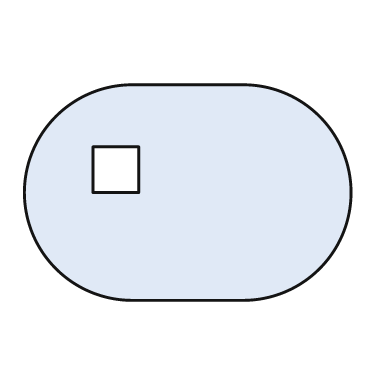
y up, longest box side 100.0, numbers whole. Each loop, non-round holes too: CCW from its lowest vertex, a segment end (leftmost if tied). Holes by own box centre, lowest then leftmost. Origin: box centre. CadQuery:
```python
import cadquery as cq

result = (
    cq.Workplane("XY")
    .moveTo(-17.0, -33.0)
    .lineTo(17.0, -33.0)
    .threePointArc((50.0, 0.0), (17.0, 33.0))
    .lineTo(-17.0, 33.0)
    .threePointArc((-50.0, 0.0), (-17.0, -33.0))
    .close()
    .moveTo(-29.0, 0.0)
    .lineTo(-15.0, 0.0)
    .lineTo(-15.0, 14.0)
    .lineTo(-29.0, 14.0)
    .close()
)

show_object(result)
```